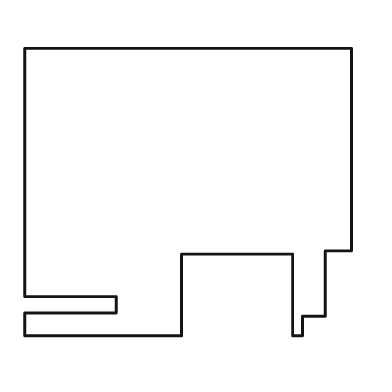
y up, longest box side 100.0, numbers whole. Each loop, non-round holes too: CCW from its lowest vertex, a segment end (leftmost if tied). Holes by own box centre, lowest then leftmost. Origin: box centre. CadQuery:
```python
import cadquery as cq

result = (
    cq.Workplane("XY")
    .moveTo(-50.0, -44.0)
    .lineTo(-2.0, -44.0)
    .lineTo(-2.0, -19.0)
    .lineTo(32.0, -19.0)
    .lineTo(32.0, -44.0)
    .lineTo(35.0, -44.0)
    .lineTo(35.0, -38.0)
    .lineTo(42.0, -38.0)
    .lineTo(42.0, -18.0)
    .lineTo(50.0, -18.0)
    .lineTo(50.0, 44.0)
    .lineTo(-50.0, 44.0)
    .lineTo(-50.0, -32.0)
    .lineTo(-22.0, -32.0)
    .lineTo(-22.0, -37.0)
    .lineTo(-50.0, -37.0)
    .close()
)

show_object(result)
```